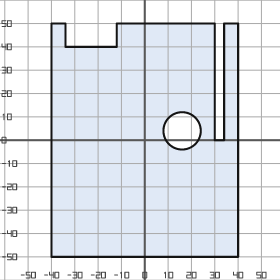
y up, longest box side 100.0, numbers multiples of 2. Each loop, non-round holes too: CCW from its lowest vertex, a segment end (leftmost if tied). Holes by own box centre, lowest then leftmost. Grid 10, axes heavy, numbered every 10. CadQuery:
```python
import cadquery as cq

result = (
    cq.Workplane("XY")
    .moveTo(-40.0, -50.0)
    .lineTo(40.0, -50.0)
    .lineTo(40.0, 50.0)
    .lineTo(34.0, 50.0)
    .lineTo(34.0, 0.0)
    .lineTo(30.0, 0.0)
    .lineTo(30.0, 50.0)
    .lineTo(-12.0, 50.0)
    .lineTo(-12.0, 40.0)
    .lineTo(-34.0, 40.0)
    .lineTo(-34.0, 50.0)
    .lineTo(-40.0, 50.0)
    .close()
    .moveTo(16.0, 4.0)
    .circle(8.0)
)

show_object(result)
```